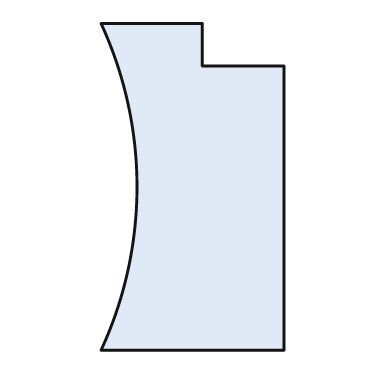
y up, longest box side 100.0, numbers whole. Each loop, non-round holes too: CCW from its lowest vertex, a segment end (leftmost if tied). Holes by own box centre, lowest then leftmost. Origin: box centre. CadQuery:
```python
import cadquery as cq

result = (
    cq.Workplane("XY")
    .moveTo(-28.0, -50.0)
    .lineTo(28.0, -50.0)
    .lineTo(28.0, 37.0)
    .lineTo(3.0, 37.0)
    .lineTo(3.0, 50.0)
    .lineTo(-28.0, 50.0)
    .threePointArc((-17.0, 0.0), (-28.0, -50.0))
    .close()
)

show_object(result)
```